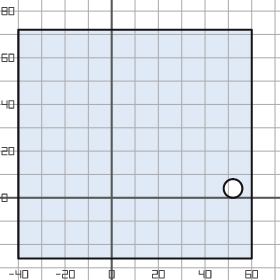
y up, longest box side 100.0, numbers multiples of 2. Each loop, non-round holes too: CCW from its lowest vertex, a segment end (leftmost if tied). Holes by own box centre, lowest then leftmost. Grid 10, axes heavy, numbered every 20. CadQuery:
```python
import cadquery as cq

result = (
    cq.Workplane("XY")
    .moveTo(-40.0, -26.0)
    .lineTo(60.0, -26.0)
    .lineTo(60.0, 72.0)
    .lineTo(-40.0, 72.0)
    .close()
    .moveTo(52.0, 4.0)
    .circle(4.0)
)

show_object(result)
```